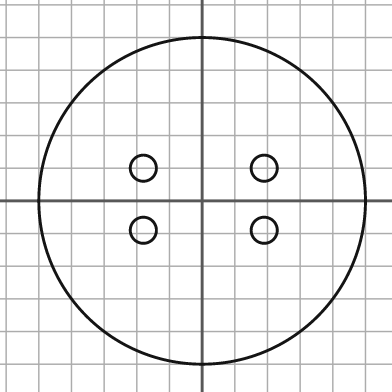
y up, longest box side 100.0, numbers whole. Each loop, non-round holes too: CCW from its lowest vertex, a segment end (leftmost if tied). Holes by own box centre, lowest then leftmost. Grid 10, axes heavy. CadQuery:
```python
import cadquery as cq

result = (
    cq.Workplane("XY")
    .moveTo(0.0, 0.0)
    .circle(50.0)
    .moveTo(-18.0, -9.0)
    .circle(4.0)
    .moveTo(19.0, -9.0)
    .circle(4.0)
    .moveTo(-18.0, 10.0)
    .circle(4.0)
    .moveTo(19.0, 10.0)
    .circle(4.0)
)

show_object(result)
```